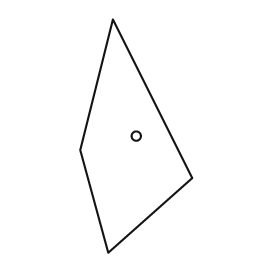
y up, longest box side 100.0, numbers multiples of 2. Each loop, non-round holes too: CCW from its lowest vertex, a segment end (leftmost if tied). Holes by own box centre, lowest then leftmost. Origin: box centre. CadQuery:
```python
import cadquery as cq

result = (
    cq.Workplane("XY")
    .moveTo(-12.0, -50.0)
    .lineTo(24.0, -18.0)
    .lineTo(-10.0, 50.0)
    .lineTo(-24.0, -6.0)
    .close()
    .moveTo(0.0, 0.0)
    .circle(2.0)
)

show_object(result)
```